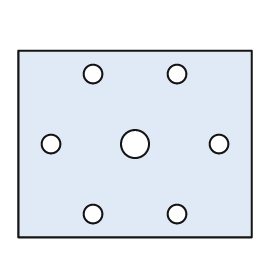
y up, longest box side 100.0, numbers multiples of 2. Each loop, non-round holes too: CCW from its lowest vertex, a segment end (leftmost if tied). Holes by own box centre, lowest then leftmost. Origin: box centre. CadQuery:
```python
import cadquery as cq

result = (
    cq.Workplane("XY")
    .moveTo(-50.0, -40.0)
    .lineTo(50.0, -40.0)
    .lineTo(50.0, 40.0)
    .lineTo(-50.0, 40.0)
    .close()
    .moveTo(-18.0, -30.0)
    .circle(4.0)
    .moveTo(18.0, -30.0)
    .circle(4.0)
    .moveTo(-36.0, 0.0)
    .circle(4.0)
    .moveTo(0.0, 0.0)
    .circle(6.0)
    .moveTo(36.0, 0.0)
    .circle(4.0)
    .moveTo(-18.0, 30.0)
    .circle(4.0)
    .moveTo(18.0, 30.0)
    .circle(4.0)
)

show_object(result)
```